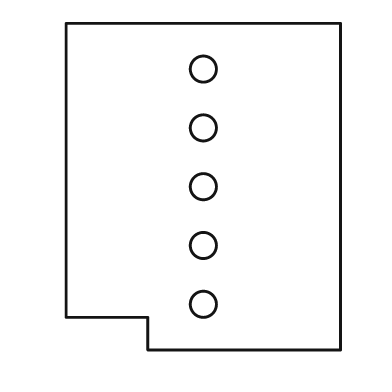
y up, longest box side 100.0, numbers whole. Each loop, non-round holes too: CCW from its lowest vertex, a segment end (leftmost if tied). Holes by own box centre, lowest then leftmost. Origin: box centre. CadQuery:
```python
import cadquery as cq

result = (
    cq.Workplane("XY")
    .moveTo(-17.0, -50.0)
    .lineTo(42.0, -50.0)
    .lineTo(42.0, 50.0)
    .lineTo(-42.0, 50.0)
    .lineTo(-42.0, -40.0)
    .lineTo(-17.0, -40.0)
    .close()
    .moveTo(0.0, -36.0)
    .circle(4.0)
    .moveTo(0.0, -18.0)
    .circle(4.0)
    .moveTo(0.0, 0.0)
    .circle(4.0)
    .moveTo(0.0, 18.0)
    .circle(4.0)
    .moveTo(0.0, 36.0)
    .circle(4.0)
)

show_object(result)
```